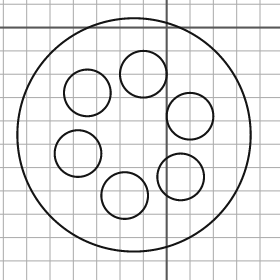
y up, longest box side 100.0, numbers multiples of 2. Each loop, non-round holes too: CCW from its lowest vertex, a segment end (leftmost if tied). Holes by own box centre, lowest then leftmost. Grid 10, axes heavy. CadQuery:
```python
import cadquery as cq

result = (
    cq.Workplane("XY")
    .moveTo(-14.0, -46.0)
    .circle(50.0)
    .moveTo(-18.0, -72.0)
    .circle(10.0)
    .moveTo(6.0, -64.0)
    .circle(10.0)
    .moveTo(-38.0, -54.0)
    .circle(10.0)
    .moveTo(10.0, -38.0)
    .circle(10.0)
    .moveTo(-34.0, -28.0)
    .circle(10.0)
    .moveTo(-10.0, -20.0)
    .circle(10.0)
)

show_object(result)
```